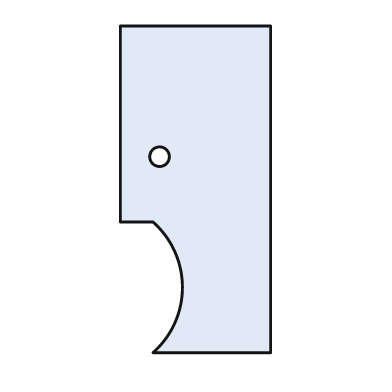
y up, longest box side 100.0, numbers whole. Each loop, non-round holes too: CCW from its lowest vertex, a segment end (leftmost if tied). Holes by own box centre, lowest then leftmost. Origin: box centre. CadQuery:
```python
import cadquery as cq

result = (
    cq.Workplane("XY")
    .moveTo(-13.0, -50.0)
    .lineTo(23.0, -50.0)
    .lineTo(23.0, 50.0)
    .lineTo(-23.0, 50.0)
    .lineTo(-23.0, -10.0)
    .lineTo(-13.0, -10.0)
    .threePointArc((-4.0, -30.0), (-13.0, -50.0))
    .close()
    .moveTo(-11.0, 10.0)
    .circle(3.0)
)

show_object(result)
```